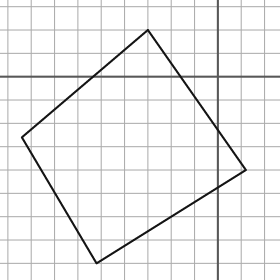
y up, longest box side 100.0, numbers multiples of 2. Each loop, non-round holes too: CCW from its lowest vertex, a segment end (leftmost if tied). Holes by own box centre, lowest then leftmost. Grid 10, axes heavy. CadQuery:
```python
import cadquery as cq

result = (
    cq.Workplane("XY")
    .moveTo(-52.0, -80.0)
    .lineTo(12.0, -40.0)
    .lineTo(-30.0, 20.0)
    .lineTo(-84.0, -26.0)
    .close()
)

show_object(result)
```